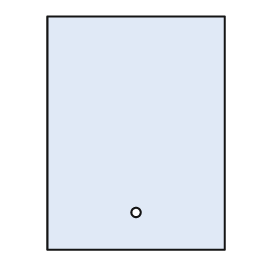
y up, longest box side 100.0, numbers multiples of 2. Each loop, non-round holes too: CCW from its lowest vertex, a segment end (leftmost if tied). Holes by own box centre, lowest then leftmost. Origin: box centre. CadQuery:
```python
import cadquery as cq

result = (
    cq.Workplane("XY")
    .moveTo(-38.0, -50.0)
    .lineTo(38.0, -50.0)
    .lineTo(38.0, 50.0)
    .lineTo(-38.0, 50.0)
    .close()
    .moveTo(0.0, -34.0)
    .circle(2.0)
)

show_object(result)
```